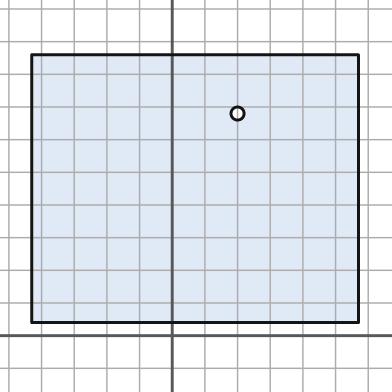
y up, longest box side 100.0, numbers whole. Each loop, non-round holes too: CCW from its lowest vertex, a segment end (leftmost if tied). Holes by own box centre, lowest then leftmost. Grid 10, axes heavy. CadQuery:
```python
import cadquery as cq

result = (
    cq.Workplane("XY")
    .moveTo(-43.0, 4.0)
    .lineTo(57.0, 4.0)
    .lineTo(57.0, 86.0)
    .lineTo(-43.0, 86.0)
    .close()
    .moveTo(20.0, 68.0)
    .circle(2.0)
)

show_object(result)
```